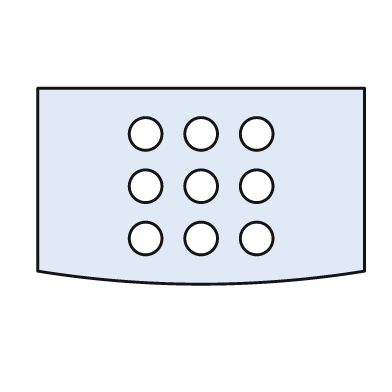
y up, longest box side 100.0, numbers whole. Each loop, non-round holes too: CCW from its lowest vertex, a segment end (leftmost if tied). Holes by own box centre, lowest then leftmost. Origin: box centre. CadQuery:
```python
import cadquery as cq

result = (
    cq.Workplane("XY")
    .moveTo(-50.0, -26.0)
    .threePointArc((0.0, -30.0), (50.0, -26.0))
    .lineTo(50.0, 30.0)
    .lineTo(-50.0, 30.0)
    .close()
    .moveTo(-17.0, -16.0)
    .circle(5.0)
    .moveTo(0.0, -16.0)
    .circle(5.0)
    .moveTo(17.0, -16.0)
    .circle(5.0)
    .moveTo(-17.0, 0.0)
    .circle(5.0)
    .moveTo(0.0, 0.0)
    .circle(5.0)
    .moveTo(17.0, 0.0)
    .circle(5.0)
    .moveTo(-17.0, 16.0)
    .circle(5.0)
    .moveTo(0.0, 16.0)
    .circle(5.0)
    .moveTo(17.0, 16.0)
    .circle(5.0)
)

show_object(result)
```